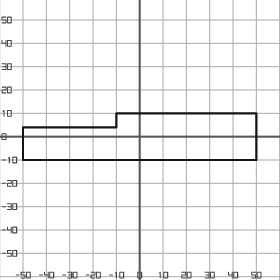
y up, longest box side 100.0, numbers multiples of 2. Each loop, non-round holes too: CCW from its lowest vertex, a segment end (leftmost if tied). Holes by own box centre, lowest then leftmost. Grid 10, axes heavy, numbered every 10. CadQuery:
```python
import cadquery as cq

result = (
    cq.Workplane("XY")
    .moveTo(-50.0, -10.0)
    .lineTo(50.0, -10.0)
    .lineTo(50.0, 10.0)
    .lineTo(-10.0, 10.0)
    .lineTo(-10.0, 4.0)
    .lineTo(-50.0, 4.0)
    .close()
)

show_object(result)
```